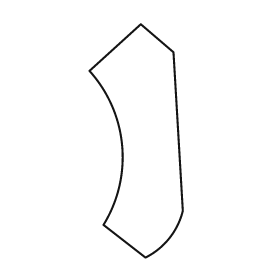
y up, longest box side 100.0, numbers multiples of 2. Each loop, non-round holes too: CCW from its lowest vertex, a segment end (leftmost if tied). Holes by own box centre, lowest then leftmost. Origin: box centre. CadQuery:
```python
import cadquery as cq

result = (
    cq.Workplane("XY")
    .moveTo(4.0, -50.0)
    .threePointArc((14.0, -42.0), (20.0, -30.0))
    .lineTo(16.0, 38.0)
    .lineTo(2.0, 50.0)
    .lineTo(-20.0, 30.0)
    .threePointArc((-6.0, -2.0), (-14.0, -36.0))
    .close()
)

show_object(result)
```